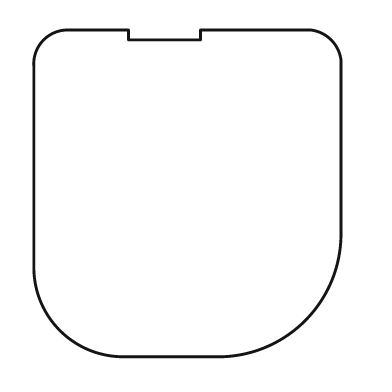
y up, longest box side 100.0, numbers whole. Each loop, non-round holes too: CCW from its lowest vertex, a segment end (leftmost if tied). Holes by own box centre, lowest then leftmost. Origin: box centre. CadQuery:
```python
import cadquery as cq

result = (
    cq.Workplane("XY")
    .moveTo(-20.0, -50.0)
    .lineTo(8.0, -50.0)
    .threePointArc((36.0, -39.0), (47.0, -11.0))
    .lineTo(47.0, 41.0)
    .threePointArc((44.0, 47.0), (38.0, 50.0))
    .lineTo(4.0, 50.0)
    .lineTo(4.0, 47.0)
    .lineTo(-18.0, 47.0)
    .lineTo(-18.0, 50.0)
    .lineTo(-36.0, 50.0)
    .threePointArc((-44.0, 47.0), (-47.0, 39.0))
    .lineTo(-47.0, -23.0)
    .threePointArc((-39.0, -42.0), (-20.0, -50.0))
    .close()
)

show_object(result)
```